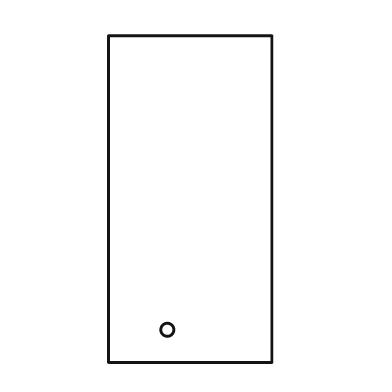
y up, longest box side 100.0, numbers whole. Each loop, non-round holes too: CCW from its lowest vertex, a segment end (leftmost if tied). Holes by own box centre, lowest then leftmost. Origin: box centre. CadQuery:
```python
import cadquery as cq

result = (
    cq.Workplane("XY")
    .moveTo(-25.0, -50.0)
    .lineTo(25.0, -50.0)
    .lineTo(25.0, 50.0)
    .lineTo(-25.0, 50.0)
    .close()
    .moveTo(-7.0, -40.0)
    .circle(2.0)
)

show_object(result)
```